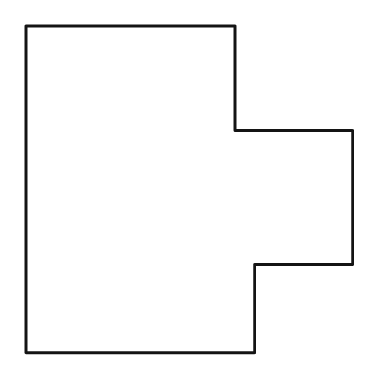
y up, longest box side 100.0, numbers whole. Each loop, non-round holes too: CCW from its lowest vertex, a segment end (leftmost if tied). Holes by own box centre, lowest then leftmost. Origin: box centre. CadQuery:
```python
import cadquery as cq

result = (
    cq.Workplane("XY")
    .moveTo(-50.0, -50.0)
    .lineTo(20.0, -50.0)
    .lineTo(20.0, -23.0)
    .lineTo(50.0, -23.0)
    .lineTo(50.0, 18.0)
    .lineTo(14.0, 18.0)
    .lineTo(14.0, 50.0)
    .lineTo(-50.0, 50.0)
    .close()
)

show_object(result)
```